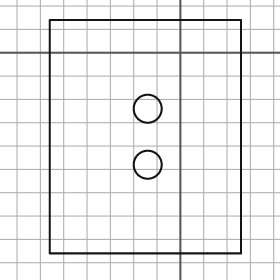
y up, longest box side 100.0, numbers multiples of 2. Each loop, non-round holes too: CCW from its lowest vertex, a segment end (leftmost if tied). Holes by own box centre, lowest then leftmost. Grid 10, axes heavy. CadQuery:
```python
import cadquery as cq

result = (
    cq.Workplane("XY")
    .moveTo(-56.0, -86.0)
    .lineTo(26.0, -86.0)
    .lineTo(26.0, 14.0)
    .lineTo(-56.0, 14.0)
    .close()
    .moveTo(-14.0, -48.0)
    .circle(6.0)
    .moveTo(-14.0, -24.0)
    .circle(6.0)
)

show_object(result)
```